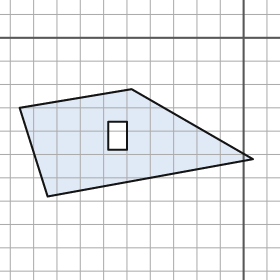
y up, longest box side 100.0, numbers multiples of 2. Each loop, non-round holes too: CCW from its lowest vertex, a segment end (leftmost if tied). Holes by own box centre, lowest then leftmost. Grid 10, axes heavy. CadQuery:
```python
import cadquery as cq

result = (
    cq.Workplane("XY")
    .moveTo(-84.0, -68.0)
    .lineTo(4.0, -52.0)
    .lineTo(-48.0, -22.0)
    .lineTo(-96.0, -30.0)
    .close()
    .moveTo(-58.0, -48.0)
    .lineTo(-50.0, -48.0)
    .lineTo(-50.0, -36.0)
    .lineTo(-58.0, -36.0)
    .close()
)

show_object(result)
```